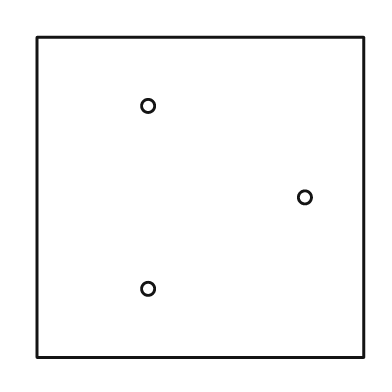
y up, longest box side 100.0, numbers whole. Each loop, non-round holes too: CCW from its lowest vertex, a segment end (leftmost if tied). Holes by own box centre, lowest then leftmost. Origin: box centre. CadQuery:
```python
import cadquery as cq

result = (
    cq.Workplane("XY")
    .moveTo(-50.0, -49.0)
    .lineTo(50.0, -49.0)
    .lineTo(50.0, 49.0)
    .lineTo(-50.0, 49.0)
    .close()
    .moveTo(-16.0, -28.0)
    .circle(2.0)
    .moveTo(32.0, 0.0)
    .circle(2.0)
    .moveTo(-16.0, 28.0)
    .circle(2.0)
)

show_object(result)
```